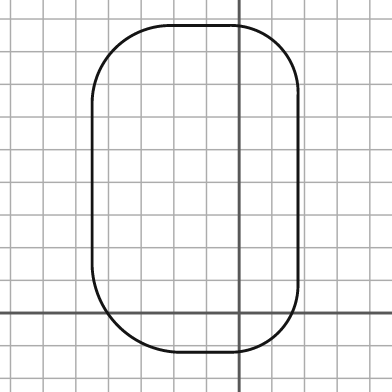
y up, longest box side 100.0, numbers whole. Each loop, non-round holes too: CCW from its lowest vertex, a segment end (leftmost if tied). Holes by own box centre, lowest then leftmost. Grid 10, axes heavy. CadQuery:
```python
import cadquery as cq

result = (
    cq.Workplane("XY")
    .moveTo(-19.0, -12.0)
    .lineTo(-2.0, -12.0)
    .threePointArc((12.0, -6.0), (18.0, 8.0))
    .lineTo(18.0, 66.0)
    .threePointArc((12.0, 82.0), (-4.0, 88.0))
    .lineTo(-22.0, 88.0)
    .threePointArc((-38.0, 81.0), (-45.0, 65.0))
    .lineTo(-45.0, 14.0)
    .threePointArc((-37.0, -4.0), (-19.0, -12.0))
    .close()
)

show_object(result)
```